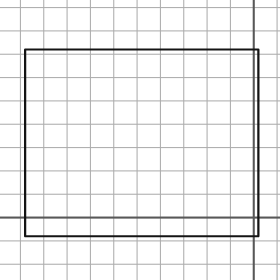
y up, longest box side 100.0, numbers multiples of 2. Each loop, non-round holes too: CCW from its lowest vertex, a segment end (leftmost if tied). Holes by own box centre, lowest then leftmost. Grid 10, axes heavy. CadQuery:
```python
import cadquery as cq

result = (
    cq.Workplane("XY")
    .moveTo(-98.0, -8.0)
    .lineTo(2.0, -8.0)
    .lineTo(2.0, 72.0)
    .lineTo(-98.0, 72.0)
    .close()
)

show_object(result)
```